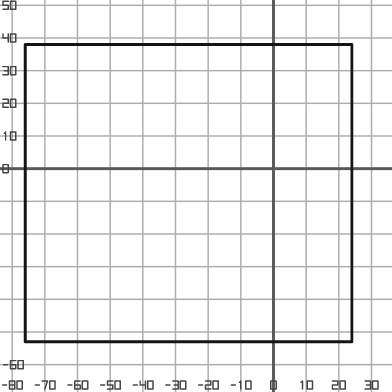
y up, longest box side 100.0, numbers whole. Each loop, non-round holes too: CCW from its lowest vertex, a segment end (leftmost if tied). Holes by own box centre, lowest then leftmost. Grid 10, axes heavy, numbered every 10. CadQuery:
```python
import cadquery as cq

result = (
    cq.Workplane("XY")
    .moveTo(-76.0, -53.0)
    .lineTo(24.0, -53.0)
    .lineTo(24.0, 38.0)
    .lineTo(-76.0, 38.0)
    .close()
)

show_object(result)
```